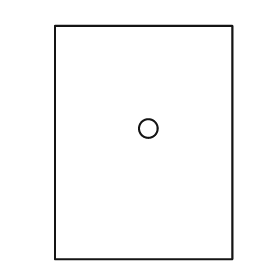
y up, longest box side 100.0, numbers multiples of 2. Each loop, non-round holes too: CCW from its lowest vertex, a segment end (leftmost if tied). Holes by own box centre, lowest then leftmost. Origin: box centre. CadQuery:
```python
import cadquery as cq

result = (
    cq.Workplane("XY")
    .moveTo(-38.0, -50.0)
    .lineTo(38.0, -50.0)
    .lineTo(38.0, 50.0)
    .lineTo(-38.0, 50.0)
    .close()
    .moveTo(2.0, 6.0)
    .circle(4.0)
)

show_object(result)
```